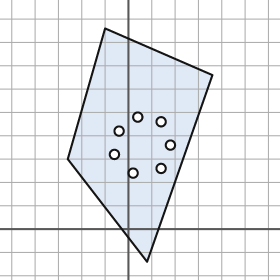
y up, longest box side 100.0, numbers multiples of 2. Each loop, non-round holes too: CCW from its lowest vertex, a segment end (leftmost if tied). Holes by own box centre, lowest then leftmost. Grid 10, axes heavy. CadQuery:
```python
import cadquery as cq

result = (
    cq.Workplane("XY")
    .moveTo(8.0, -14.0)
    .lineTo(36.0, 66.0)
    .lineTo(-10.0, 86.0)
    .lineTo(-26.0, 30.0)
    .close()
    .moveTo(2.0, 24.0)
    .circle(2.0)
    .moveTo(14.0, 26.0)
    .circle(2.0)
    .moveTo(-6.0, 32.0)
    .circle(2.0)
    .moveTo(18.0, 36.0)
    .circle(2.0)
    .moveTo(-4.0, 42.0)
    .circle(2.0)
    .moveTo(14.0, 46.0)
    .circle(2.0)
    .moveTo(4.0, 48.0)
    .circle(2.0)
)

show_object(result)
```